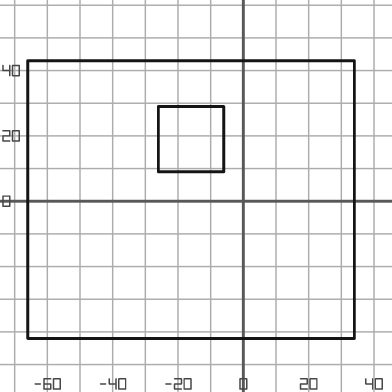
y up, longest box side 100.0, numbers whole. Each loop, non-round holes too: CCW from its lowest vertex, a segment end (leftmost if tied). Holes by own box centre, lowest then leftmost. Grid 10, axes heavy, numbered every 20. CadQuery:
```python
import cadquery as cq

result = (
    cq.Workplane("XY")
    .moveTo(-66.0, -42.0)
    .lineTo(34.0, -42.0)
    .lineTo(34.0, 43.0)
    .lineTo(-66.0, 43.0)
    .close()
    .moveTo(-26.0, 9.0)
    .lineTo(-6.0, 9.0)
    .lineTo(-6.0, 29.0)
    .lineTo(-26.0, 29.0)
    .close()
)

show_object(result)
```